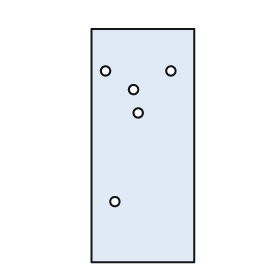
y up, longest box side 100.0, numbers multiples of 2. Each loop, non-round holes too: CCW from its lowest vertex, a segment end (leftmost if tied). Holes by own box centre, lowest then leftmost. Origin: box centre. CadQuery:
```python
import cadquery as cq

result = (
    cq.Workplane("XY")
    .moveTo(-22.0, -50.0)
    .lineTo(22.0, -50.0)
    .lineTo(22.0, 50.0)
    .lineTo(-22.0, 50.0)
    .close()
    .moveTo(-12.0, -24.0)
    .circle(2.0)
    .moveTo(-2.0, 14.0)
    .circle(2.0)
    .moveTo(-4.0, 24.0)
    .circle(2.0)
    .moveTo(-16.0, 32.0)
    .circle(2.0)
    .moveTo(12.0, 32.0)
    .circle(2.0)
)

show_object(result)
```